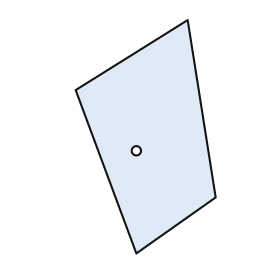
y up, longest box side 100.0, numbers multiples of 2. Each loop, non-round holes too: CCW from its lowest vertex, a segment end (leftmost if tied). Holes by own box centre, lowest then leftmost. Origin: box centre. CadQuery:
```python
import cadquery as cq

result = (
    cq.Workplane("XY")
    .moveTo(-4.0, -50.0)
    .lineTo(30.0, -26.0)
    .lineTo(18.0, 50.0)
    .lineTo(-30.0, 20.0)
    .close()
    .moveTo(-4.0, -6.0)
    .circle(2.0)
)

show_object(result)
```